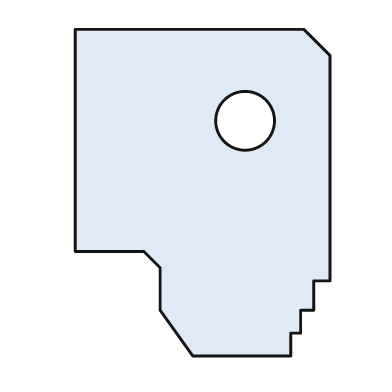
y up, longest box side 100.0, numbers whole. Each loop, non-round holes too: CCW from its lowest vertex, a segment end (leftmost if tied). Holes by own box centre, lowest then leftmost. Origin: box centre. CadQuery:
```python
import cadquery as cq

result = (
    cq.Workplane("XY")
    .moveTo(-3.0, -50.0)
    .lineTo(27.0, -50.0)
    .lineTo(27.0, -43.0)
    .lineTo(30.0, -43.0)
    .lineTo(30.0, -36.0)
    .lineTo(34.0, -36.0)
    .lineTo(34.0, -27.0)
    .lineTo(39.0, -27.0)
    .lineTo(39.0, 42.0)
    .lineTo(31.0, 50.0)
    .lineTo(-39.0, 50.0)
    .lineTo(-39.0, -18.0)
    .lineTo(-18.0, -18.0)
    .lineTo(-13.0, -23.0)
    .lineTo(-13.0, -36.0)
    .close()
    .moveTo(13.0, 22.0)
    .circle(9.0)
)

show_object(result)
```